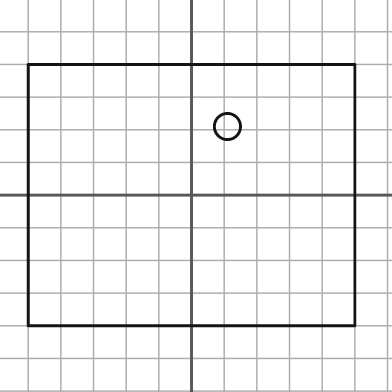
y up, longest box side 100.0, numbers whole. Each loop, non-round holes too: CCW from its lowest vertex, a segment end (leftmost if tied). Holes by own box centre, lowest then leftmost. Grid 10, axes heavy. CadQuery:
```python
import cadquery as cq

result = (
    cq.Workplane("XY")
    .moveTo(-50.0, -40.0)
    .lineTo(50.0, -40.0)
    .lineTo(50.0, 40.0)
    .lineTo(-50.0, 40.0)
    .close()
    .moveTo(11.0, 21.0)
    .circle(4.0)
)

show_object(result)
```